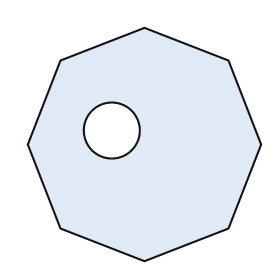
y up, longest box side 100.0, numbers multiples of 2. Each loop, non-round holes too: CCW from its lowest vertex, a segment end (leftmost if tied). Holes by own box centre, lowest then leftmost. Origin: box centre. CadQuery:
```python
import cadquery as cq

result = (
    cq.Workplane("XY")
    .moveTo(0.0, -50.0)
    .lineTo(36.0, -36.0)
    .lineTo(50.0, 0.0)
    .lineTo(36.0, 36.0)
    .lineTo(0.0, 50.0)
    .lineTo(-36.0, 36.0)
    .lineTo(-50.0, 0.0)
    .lineTo(-36.0, -36.0)
    .close()
    .moveTo(-14.0, 6.0)
    .circle(12.0)
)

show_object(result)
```